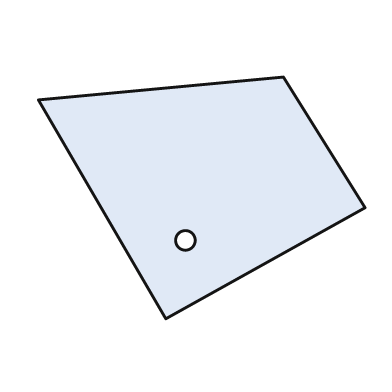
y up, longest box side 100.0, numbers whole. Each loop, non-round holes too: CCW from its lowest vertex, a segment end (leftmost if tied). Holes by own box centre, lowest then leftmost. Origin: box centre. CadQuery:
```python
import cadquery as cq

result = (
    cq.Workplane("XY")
    .moveTo(-11.0, -37.0)
    .lineTo(50.0, -3.0)
    .lineTo(25.0, 37.0)
    .lineTo(-50.0, 30.0)
    .close()
    .moveTo(-5.0, -13.0)
    .circle(3.0)
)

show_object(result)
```